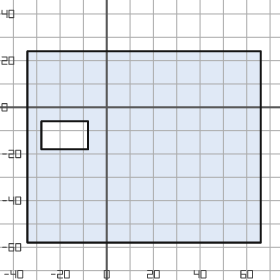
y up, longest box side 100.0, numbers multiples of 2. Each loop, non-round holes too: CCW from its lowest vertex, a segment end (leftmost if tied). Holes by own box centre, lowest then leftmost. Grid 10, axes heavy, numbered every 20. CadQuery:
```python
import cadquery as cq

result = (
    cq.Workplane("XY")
    .moveTo(-34.0, -58.0)
    .lineTo(66.0, -58.0)
    .lineTo(66.0, 24.0)
    .lineTo(-34.0, 24.0)
    .close()
    .moveTo(-28.0, -18.0)
    .lineTo(-8.0, -18.0)
    .lineTo(-8.0, -6.0)
    .lineTo(-28.0, -6.0)
    .close()
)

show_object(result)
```